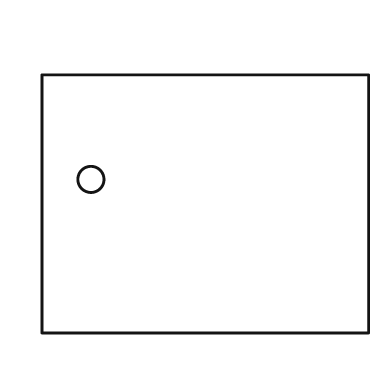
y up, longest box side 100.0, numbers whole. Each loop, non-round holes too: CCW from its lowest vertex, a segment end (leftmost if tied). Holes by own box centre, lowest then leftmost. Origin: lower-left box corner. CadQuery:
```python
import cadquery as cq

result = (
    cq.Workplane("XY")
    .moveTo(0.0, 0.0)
    .lineTo(100.0, 0.0)
    .lineTo(100.0, 79.0)
    .lineTo(0.0, 79.0)
    .close()
    .moveTo(15.0, 47.0)
    .circle(4.0)
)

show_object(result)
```